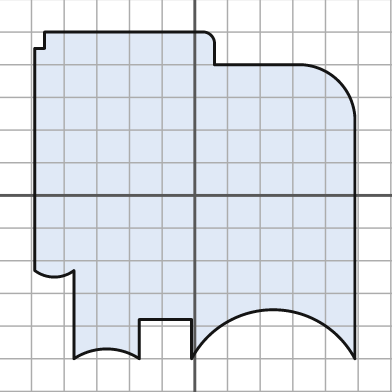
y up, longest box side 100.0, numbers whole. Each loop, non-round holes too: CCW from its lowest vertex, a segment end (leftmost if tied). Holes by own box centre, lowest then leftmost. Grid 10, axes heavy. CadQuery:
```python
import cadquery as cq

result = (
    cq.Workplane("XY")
    .moveTo(-37.0, -50.0)
    .threePointArc((-27.0, -47.0), (-17.0, -50.0))
    .lineTo(-17.0, -38.0)
    .lineTo(-1.0, -38.0)
    .lineTo(-1.0, -50.0)
    .threePointArc((24.0, -35.0), (49.0, -50.0))
    .lineTo(49.0, 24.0)
    .threePointArc((44.0, 35.0), (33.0, 40.0))
    .lineTo(6.0, 40.0)
    .lineTo(6.0, 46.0)
    .threePointArc((5.0, 49.0), (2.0, 50.0))
    .lineTo(-46.0, 50.0)
    .lineTo(-46.0, 45.0)
    .lineTo(-49.0, 45.0)
    .lineTo(-49.0, -23.0)
    .threePointArc((-43.0, -25.0), (-37.0, -23.0))
    .close()
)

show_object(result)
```